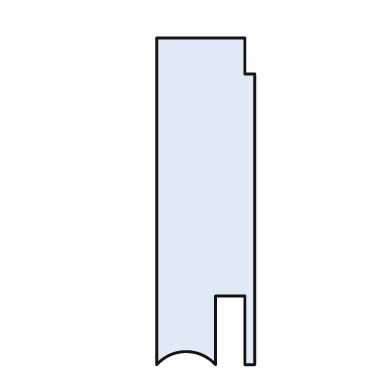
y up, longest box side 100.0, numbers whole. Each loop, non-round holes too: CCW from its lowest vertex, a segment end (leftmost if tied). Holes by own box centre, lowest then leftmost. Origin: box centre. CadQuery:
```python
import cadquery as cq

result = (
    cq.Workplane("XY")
    .moveTo(-15.0, -50.0)
    .threePointArc((-6.0, -46.0), (3.0, -50.0))
    .lineTo(3.0, -29.0)
    .lineTo(12.0, -29.0)
    .lineTo(12.0, -50.0)
    .lineTo(15.0, -50.0)
    .lineTo(15.0, 39.0)
    .lineTo(12.0, 39.0)
    .lineTo(12.0, 50.0)
    .lineTo(-15.0, 50.0)
    .close()
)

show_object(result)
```